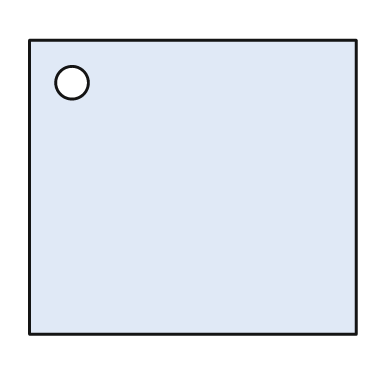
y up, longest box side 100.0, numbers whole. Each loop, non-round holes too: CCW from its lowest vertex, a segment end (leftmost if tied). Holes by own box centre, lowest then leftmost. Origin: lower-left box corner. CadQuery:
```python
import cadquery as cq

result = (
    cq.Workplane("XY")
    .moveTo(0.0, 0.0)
    .lineTo(100.0, 0.0)
    .lineTo(100.0, 90.0)
    .lineTo(0.0, 90.0)
    .close()
    .moveTo(13.0, 77.0)
    .circle(5.0)
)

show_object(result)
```